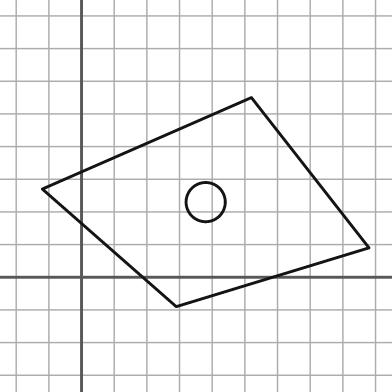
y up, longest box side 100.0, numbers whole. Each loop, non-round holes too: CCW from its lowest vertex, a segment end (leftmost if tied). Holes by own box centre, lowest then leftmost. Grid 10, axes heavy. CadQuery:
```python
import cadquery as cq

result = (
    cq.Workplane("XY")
    .moveTo(29.0, -9.0)
    .lineTo(88.0, 9.0)
    .lineTo(52.0, 55.0)
    .lineTo(-12.0, 27.0)
    .close()
    .moveTo(38.0, 23.0)
    .circle(6.0)
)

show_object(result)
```